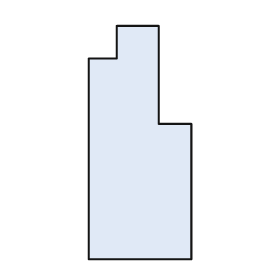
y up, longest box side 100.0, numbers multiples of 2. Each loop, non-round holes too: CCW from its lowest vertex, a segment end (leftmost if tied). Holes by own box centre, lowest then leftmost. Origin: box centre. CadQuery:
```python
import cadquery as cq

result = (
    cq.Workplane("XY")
    .moveTo(-22.0, -50.0)
    .lineTo(22.0, -50.0)
    .lineTo(22.0, 8.0)
    .lineTo(8.0, 8.0)
    .lineTo(8.0, 50.0)
    .lineTo(-10.0, 50.0)
    .lineTo(-10.0, 36.0)
    .lineTo(-22.0, 36.0)
    .close()
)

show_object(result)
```